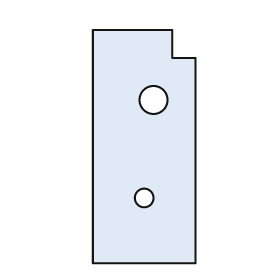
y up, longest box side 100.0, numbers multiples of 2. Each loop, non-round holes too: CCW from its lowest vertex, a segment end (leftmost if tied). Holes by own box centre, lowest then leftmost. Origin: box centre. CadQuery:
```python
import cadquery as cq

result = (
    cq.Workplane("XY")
    .moveTo(-22.0, -50.0)
    .lineTo(22.0, -50.0)
    .lineTo(22.0, 38.0)
    .lineTo(12.0, 38.0)
    .lineTo(12.0, 50.0)
    .lineTo(-22.0, 50.0)
    .close()
    .moveTo(0.0, -22.0)
    .circle(4.0)
    .moveTo(4.0, 20.0)
    .circle(6.0)
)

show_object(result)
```